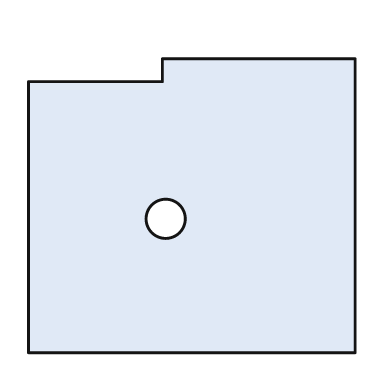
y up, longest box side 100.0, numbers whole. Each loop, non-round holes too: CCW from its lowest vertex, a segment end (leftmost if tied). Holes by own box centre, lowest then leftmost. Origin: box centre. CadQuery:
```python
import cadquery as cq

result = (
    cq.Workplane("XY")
    .moveTo(-50.0, -45.0)
    .lineTo(50.0, -45.0)
    .lineTo(50.0, 45.0)
    .lineTo(-9.0, 45.0)
    .lineTo(-9.0, 38.0)
    .lineTo(-50.0, 38.0)
    .close()
    .moveTo(-8.0, -4.0)
    .circle(6.0)
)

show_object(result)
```